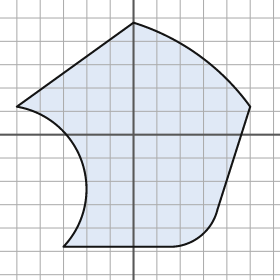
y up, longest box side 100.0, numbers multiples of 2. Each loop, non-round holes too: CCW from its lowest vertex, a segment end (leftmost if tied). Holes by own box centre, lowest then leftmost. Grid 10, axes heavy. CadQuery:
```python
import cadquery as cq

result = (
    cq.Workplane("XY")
    .moveTo(-30.0, -48.0)
    .lineTo(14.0, -48.0)
    .threePointArc((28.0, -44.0), (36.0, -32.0))
    .lineTo(50.0, 12.0)
    .threePointArc((28.0, 34.0), (0.0, 48.0))
    .lineTo(-50.0, 12.0)
    .threePointArc((-22.0, -12.0), (-30.0, -48.0))
    .close()
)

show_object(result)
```